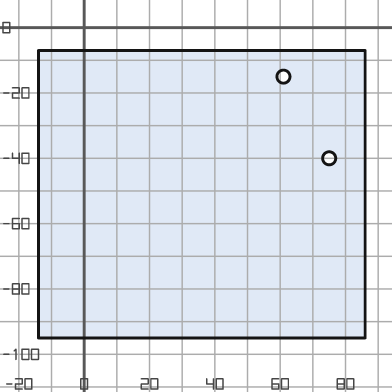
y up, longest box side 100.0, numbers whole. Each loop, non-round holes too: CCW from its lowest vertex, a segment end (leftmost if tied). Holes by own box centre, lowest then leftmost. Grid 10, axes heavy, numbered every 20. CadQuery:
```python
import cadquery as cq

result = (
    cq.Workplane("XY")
    .moveTo(-14.0, -95.0)
    .lineTo(86.0, -95.0)
    .lineTo(86.0, -7.0)
    .lineTo(-14.0, -7.0)
    .close()
    .moveTo(75.0, -40.0)
    .circle(2.0)
    .moveTo(61.0, -15.0)
    .circle(2.0)
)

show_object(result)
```